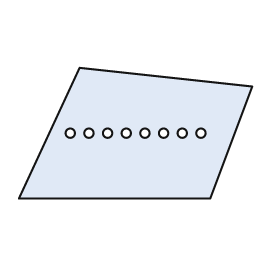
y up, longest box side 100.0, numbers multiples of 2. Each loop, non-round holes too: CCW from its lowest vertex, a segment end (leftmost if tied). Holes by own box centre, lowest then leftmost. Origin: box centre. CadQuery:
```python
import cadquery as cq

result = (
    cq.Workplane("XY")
    .moveTo(-50.0, -28.0)
    .lineTo(32.0, -28.0)
    .lineTo(50.0, 20.0)
    .lineTo(-24.0, 28.0)
    .close()
    .moveTo(-28.0, 0.0)
    .circle(2.0)
    .moveTo(-20.0, 0.0)
    .circle(2.0)
    .moveTo(-12.0, 0.0)
    .circle(2.0)
    .moveTo(-4.0, 0.0)
    .circle(2.0)
    .moveTo(4.0, 0.0)
    .circle(2.0)
    .moveTo(12.0, 0.0)
    .circle(2.0)
    .moveTo(20.0, 0.0)
    .circle(2.0)
    .moveTo(28.0, 0.0)
    .circle(2.0)
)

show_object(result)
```